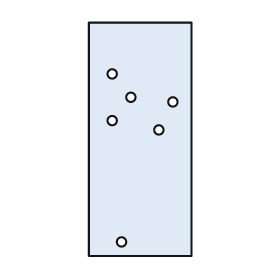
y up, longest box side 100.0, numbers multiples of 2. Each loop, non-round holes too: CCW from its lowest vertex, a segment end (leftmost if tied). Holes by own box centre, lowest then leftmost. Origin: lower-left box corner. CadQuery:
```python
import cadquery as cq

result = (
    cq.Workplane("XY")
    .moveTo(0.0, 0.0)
    .lineTo(44.0, 0.0)
    .lineTo(44.0, 100.0)
    .lineTo(0.0, 100.0)
    .close()
    .moveTo(14.0, 6.0)
    .circle(2.0)
    .moveTo(30.0, 54.0)
    .circle(2.0)
    .moveTo(10.0, 58.0)
    .circle(2.0)
    .moveTo(36.0, 66.0)
    .circle(2.0)
    .moveTo(18.0, 68.0)
    .circle(2.0)
    .moveTo(10.0, 78.0)
    .circle(2.0)
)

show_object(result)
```